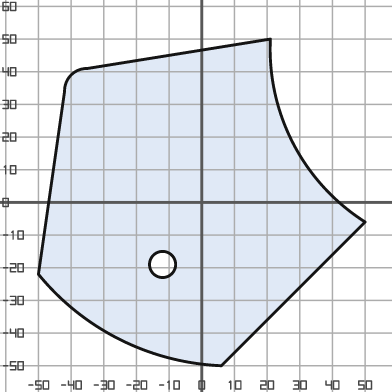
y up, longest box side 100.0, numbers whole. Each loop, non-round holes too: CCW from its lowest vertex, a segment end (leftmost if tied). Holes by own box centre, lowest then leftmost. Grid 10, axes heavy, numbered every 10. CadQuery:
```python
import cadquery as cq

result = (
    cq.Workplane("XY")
    .moveTo(6.0, -50.0)
    .lineTo(50.0, -6.0)
    .threePointArc((28.0, 18.0), (21.0, 50.0))
    .lineTo(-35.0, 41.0)
    .threePointArc((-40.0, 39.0), (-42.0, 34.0))
    .lineTo(-50.0, -22.0)
    .threePointArc((-25.0, -42.0), (6.0, -50.0))
    .close()
    .moveTo(-12.0, -19.0)
    .circle(4.0)
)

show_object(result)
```